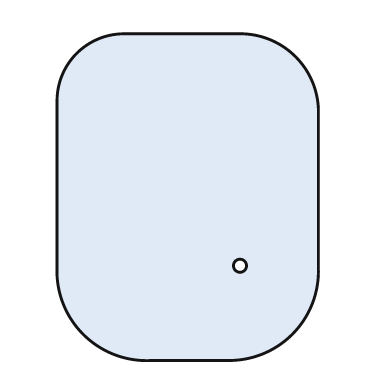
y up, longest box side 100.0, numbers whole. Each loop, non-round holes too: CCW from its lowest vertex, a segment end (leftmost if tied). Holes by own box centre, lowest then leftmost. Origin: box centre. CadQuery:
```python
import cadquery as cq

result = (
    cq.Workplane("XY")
    .moveTo(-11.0, -50.0)
    .lineTo(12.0, -50.0)
    .threePointArc((32.0, -42.0), (40.0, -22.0))
    .lineTo(40.0, 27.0)
    .threePointArc((33.0, 43.0), (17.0, 50.0))
    .lineTo(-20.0, 50.0)
    .threePointArc((-34.0, 44.0), (-40.0, 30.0))
    .lineTo(-40.0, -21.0)
    .threePointArc((-32.0, -42.0), (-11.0, -50.0))
    .close()
    .moveTo(16.0, -21.0)
    .circle(2.0)
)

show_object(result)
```